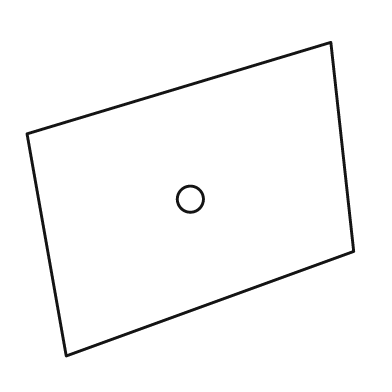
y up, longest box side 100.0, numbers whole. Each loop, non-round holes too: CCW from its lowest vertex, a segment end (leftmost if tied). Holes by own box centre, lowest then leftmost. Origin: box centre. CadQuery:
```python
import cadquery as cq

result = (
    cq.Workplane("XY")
    .moveTo(-38.0, -48.0)
    .lineTo(50.0, -16.0)
    .lineTo(43.0, 48.0)
    .lineTo(-50.0, 20.0)
    .close()
    .moveTo(0.0, 0.0)
    .circle(4.0)
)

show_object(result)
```